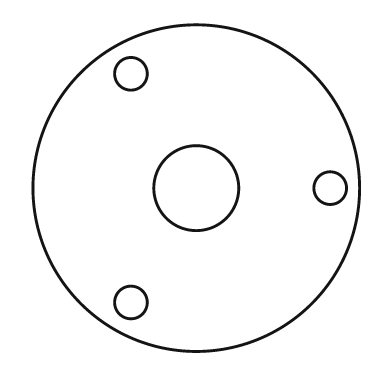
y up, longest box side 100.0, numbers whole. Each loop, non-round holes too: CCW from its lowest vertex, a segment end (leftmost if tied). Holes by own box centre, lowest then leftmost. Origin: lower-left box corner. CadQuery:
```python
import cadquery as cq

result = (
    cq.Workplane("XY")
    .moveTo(50.0, 50.0)
    .circle(50.0)
    .moveTo(30.0, 15.0)
    .circle(5.0)
    .moveTo(50.0, 50.0)
    .circle(13.0)
    .moveTo(91.0, 50.0)
    .circle(5.0)
    .moveTo(30.0, 85.0)
    .circle(5.0)
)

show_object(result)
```